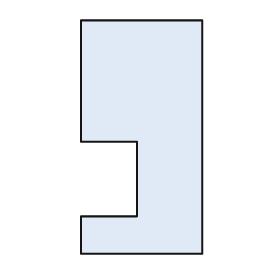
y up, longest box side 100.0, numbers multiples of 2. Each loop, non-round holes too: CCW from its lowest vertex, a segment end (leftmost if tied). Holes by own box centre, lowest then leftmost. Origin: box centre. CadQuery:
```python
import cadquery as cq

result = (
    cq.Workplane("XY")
    .moveTo(-26.0, -50.0)
    .lineTo(26.0, -50.0)
    .lineTo(26.0, 50.0)
    .lineTo(-26.0, 50.0)
    .lineTo(-26.0, -2.0)
    .lineTo(-2.0, -2.0)
    .lineTo(-2.0, -34.0)
    .lineTo(-26.0, -34.0)
    .close()
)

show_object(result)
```